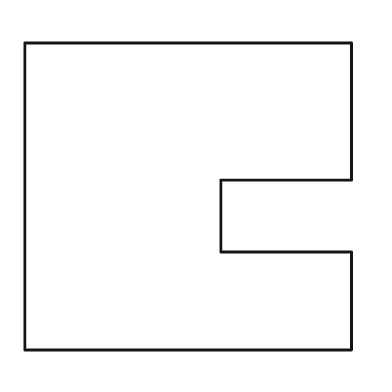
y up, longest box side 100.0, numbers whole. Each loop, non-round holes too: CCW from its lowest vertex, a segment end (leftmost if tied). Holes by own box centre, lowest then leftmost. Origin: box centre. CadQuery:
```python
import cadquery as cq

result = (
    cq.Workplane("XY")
    .moveTo(-50.0, -47.0)
    .lineTo(50.0, -47.0)
    .lineTo(50.0, -17.0)
    .lineTo(10.0, -17.0)
    .lineTo(10.0, 5.0)
    .lineTo(50.0, 5.0)
    .lineTo(50.0, 47.0)
    .lineTo(-50.0, 47.0)
    .close()
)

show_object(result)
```